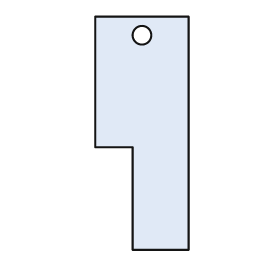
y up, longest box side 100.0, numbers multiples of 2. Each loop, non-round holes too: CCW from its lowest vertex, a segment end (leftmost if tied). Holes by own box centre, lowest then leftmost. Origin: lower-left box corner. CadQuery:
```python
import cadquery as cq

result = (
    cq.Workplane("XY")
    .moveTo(16.0, 0.0)
    .lineTo(40.0, 0.0)
    .lineTo(40.0, 100.0)
    .lineTo(0.0, 100.0)
    .lineTo(0.0, 44.0)
    .lineTo(16.0, 44.0)
    .close()
    .moveTo(20.0, 92.0)
    .circle(4.0)
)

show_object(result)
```